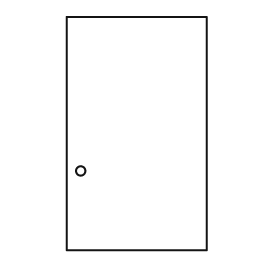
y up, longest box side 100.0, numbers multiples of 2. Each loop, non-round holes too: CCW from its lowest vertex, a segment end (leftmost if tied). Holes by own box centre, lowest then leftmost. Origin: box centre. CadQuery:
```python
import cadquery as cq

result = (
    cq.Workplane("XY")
    .moveTo(-30.0, -50.0)
    .lineTo(30.0, -50.0)
    .lineTo(30.0, 50.0)
    .lineTo(-30.0, 50.0)
    .close()
    .moveTo(-24.0, -16.0)
    .circle(2.0)
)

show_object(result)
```